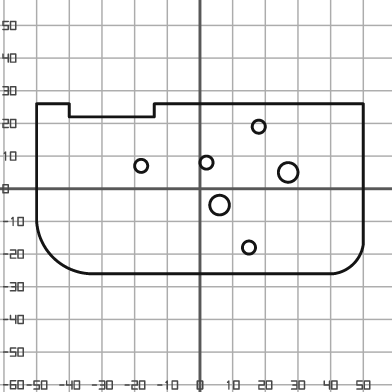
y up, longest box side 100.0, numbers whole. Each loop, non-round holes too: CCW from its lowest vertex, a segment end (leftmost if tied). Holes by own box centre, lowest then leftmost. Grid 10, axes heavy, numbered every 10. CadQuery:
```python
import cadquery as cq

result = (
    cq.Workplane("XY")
    .moveTo(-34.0, -26.0)
    .lineTo(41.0, -26.0)
    .threePointArc((47.0, -23.0), (50.0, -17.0))
    .lineTo(50.0, 26.0)
    .lineTo(-14.0, 26.0)
    .lineTo(-14.0, 22.0)
    .lineTo(-40.0, 22.0)
    .lineTo(-40.0, 26.0)
    .lineTo(-50.0, 26.0)
    .lineTo(-50.0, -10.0)
    .threePointArc((-45.0, -21.0), (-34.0, -26.0))
    .close()
    .moveTo(15.0, -18.0)
    .circle(2.0)
    .moveTo(6.0, -5.0)
    .circle(3.0)
    .moveTo(27.0, 5.0)
    .circle(3.0)
    .moveTo(-18.0, 7.0)
    .circle(2.0)
    .moveTo(2.0, 8.0)
    .circle(2.0)
    .moveTo(18.0, 19.0)
    .circle(2.0)
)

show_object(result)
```